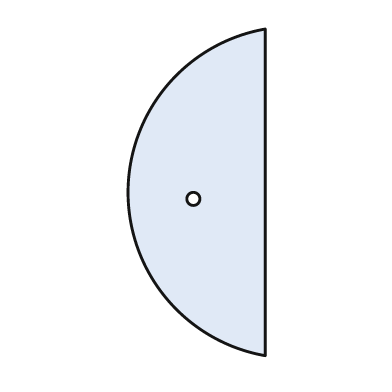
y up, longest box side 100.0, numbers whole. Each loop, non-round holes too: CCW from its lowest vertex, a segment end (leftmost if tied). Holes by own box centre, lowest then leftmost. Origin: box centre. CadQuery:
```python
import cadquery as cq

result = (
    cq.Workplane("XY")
    .moveTo(21.0, -50.0)
    .lineTo(21.0, 50.0)
    .threePointArc((-21.0, 0.0), (21.0, -50.0))
    .close()
    .moveTo(-1.0, -2.0)
    .circle(2.0)
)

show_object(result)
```